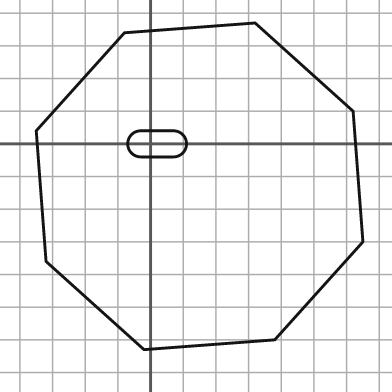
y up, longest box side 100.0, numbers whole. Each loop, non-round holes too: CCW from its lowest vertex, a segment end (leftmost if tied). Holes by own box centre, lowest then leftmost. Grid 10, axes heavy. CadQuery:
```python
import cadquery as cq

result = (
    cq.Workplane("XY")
    .moveTo(-2.0, -63.0)
    .lineTo(38.0, -60.0)
    .lineTo(65.0, -30.0)
    .lineTo(62.0, 10.0)
    .lineTo(32.0, 37.0)
    .lineTo(-8.0, 34.0)
    .lineTo(-35.0, 4.0)
    .lineTo(-32.0, -36.0)
    .close()
    .moveTo(-3.0, -4.0)
    .lineTo(7.0, -4.0)
    .threePointArc((11.0, 0.0), (7.0, 4.0))
    .lineTo(-3.0, 4.0)
    .threePointArc((-7.0, 0.0), (-3.0, -4.0))
    .close()
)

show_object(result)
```